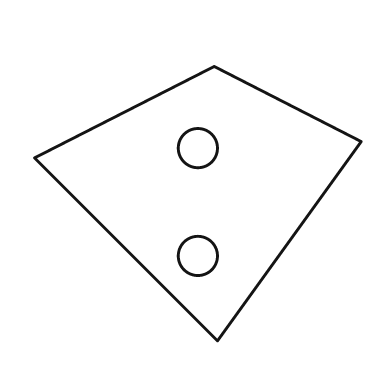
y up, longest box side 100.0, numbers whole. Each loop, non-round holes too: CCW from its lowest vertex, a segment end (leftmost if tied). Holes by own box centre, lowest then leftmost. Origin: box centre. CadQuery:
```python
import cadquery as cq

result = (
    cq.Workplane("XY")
    .moveTo(6.0, -42.0)
    .lineTo(50.0, 19.0)
    .lineTo(5.0, 42.0)
    .lineTo(-50.0, 14.0)
    .close()
    .moveTo(0.0, -16.0)
    .circle(6.0)
    .moveTo(0.0, 17.0)
    .circle(6.0)
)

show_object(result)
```